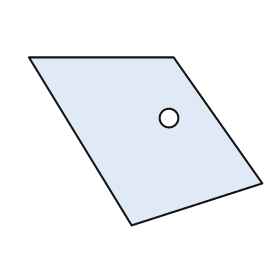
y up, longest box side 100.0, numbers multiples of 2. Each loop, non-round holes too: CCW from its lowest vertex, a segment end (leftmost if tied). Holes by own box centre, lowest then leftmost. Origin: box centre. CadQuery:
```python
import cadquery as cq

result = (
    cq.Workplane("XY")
    .moveTo(-6.0, -36.0)
    .lineTo(50.0, -18.0)
    .lineTo(12.0, 36.0)
    .lineTo(-50.0, 36.0)
    .close()
    .moveTo(10.0, 10.0)
    .circle(4.0)
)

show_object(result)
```